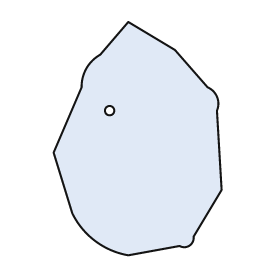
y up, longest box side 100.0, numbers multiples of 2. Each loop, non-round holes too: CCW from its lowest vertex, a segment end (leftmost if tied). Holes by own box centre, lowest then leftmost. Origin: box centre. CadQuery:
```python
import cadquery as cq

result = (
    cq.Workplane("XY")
    .moveTo(-4.0, -50.0)
    .lineTo(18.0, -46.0)
    .threePointArc((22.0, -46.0), (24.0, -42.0))
    .lineTo(36.0, -22.0)
    .lineTo(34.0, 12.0)
    .threePointArc((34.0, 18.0), (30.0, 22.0))
    .lineTo(16.0, 38.0)
    .lineTo(-4.0, 50.0)
    .lineTo(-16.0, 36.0)
    .threePointArc((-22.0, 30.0), (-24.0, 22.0))
    .lineTo(-36.0, -6.0)
    .lineTo(-28.0, -32.0)
    .threePointArc((-18.0, -44.0), (-4.0, -50.0))
    .close()
    .moveTo(-12.0, 12.0)
    .circle(2.0)
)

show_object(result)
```